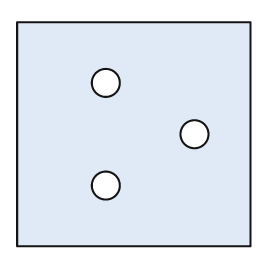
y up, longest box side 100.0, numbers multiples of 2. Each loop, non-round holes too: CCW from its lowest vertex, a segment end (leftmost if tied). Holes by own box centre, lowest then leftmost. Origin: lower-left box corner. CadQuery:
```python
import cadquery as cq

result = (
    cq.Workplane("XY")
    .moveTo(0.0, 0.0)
    .lineTo(100.0, 0.0)
    .lineTo(100.0, 96.0)
    .lineTo(0.0, 96.0)
    .close()
    .moveTo(38.0, 26.0)
    .circle(6.0)
    .moveTo(76.0, 48.0)
    .circle(6.0)
    .moveTo(38.0, 70.0)
    .circle(6.0)
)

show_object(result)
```